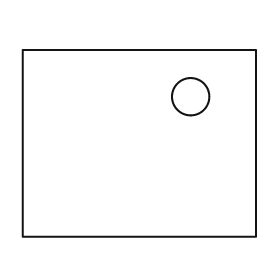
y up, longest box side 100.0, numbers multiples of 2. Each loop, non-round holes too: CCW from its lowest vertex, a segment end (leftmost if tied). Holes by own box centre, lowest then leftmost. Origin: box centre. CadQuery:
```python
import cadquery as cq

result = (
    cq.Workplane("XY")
    .moveTo(-50.0, -40.0)
    .lineTo(50.0, -40.0)
    .lineTo(50.0, 40.0)
    .lineTo(-50.0, 40.0)
    .close()
    .moveTo(22.0, 20.0)
    .circle(8.0)
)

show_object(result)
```